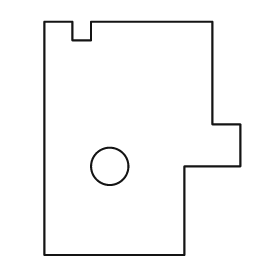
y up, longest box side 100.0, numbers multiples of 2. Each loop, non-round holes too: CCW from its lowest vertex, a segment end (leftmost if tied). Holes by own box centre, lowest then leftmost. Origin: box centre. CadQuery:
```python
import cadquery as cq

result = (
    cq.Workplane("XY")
    .moveTo(-42.0, -50.0)
    .lineTo(18.0, -50.0)
    .lineTo(18.0, -12.0)
    .lineTo(42.0, -12.0)
    .lineTo(42.0, 6.0)
    .lineTo(30.0, 6.0)
    .lineTo(30.0, 50.0)
    .lineTo(-22.0, 50.0)
    .lineTo(-22.0, 42.0)
    .lineTo(-30.0, 42.0)
    .lineTo(-30.0, 50.0)
    .lineTo(-42.0, 50.0)
    .close()
    .moveTo(-14.0, -12.0)
    .circle(8.0)
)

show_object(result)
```